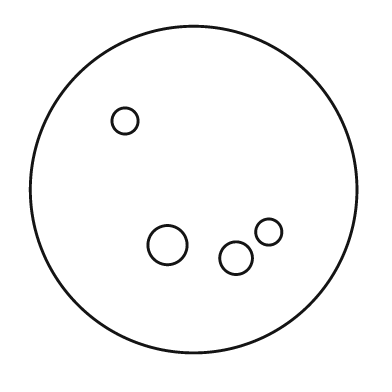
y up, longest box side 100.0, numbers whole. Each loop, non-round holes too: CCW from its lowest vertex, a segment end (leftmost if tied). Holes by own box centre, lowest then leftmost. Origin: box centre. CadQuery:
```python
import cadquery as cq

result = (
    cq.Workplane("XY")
    .moveTo(0.0, 0.0)
    .circle(50.0)
    .moveTo(13.0, -21.0)
    .circle(5.0)
    .moveTo(-8.0, -17.0)
    .circle(6.0)
    .moveTo(23.0, -13.0)
    .circle(4.0)
    .moveTo(-21.0, 21.0)
    .circle(4.0)
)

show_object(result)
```